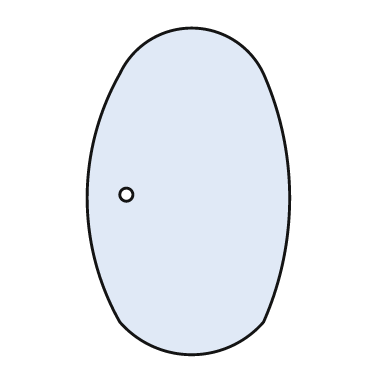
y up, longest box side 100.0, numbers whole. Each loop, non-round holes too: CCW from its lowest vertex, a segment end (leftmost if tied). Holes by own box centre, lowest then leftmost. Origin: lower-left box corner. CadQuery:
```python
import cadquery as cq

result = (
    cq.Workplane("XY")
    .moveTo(10.0, 10.0)
    .threePointArc((32.0, 0.0), (54.0, 10.0))
    .threePointArc((62.0, 48.0), (54.0, 86.0))
    .threePointArc((32.0, 100.0), (10.0, 86.0))
    .threePointArc((0.0, 48.0), (10.0, 10.0))
    .close()
    .moveTo(12.0, 49.0)
    .circle(2.0)
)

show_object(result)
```